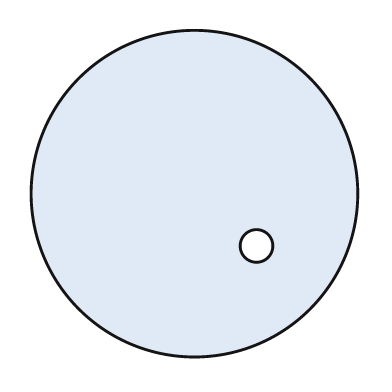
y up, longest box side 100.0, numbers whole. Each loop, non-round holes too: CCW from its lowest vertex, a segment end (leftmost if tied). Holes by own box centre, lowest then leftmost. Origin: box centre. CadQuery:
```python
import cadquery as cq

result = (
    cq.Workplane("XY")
    .moveTo(0.0, 0.0)
    .circle(50.0)
    .moveTo(19.0, -16.0)
    .circle(5.0)
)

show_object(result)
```